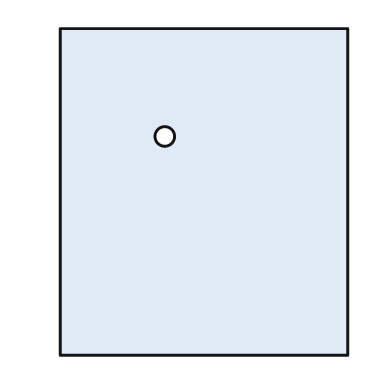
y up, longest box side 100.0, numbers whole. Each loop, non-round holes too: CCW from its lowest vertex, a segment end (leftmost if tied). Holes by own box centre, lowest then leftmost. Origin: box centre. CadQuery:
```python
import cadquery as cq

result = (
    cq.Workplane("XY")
    .moveTo(-44.0, -50.0)
    .lineTo(44.0, -50.0)
    .lineTo(44.0, 50.0)
    .lineTo(-44.0, 50.0)
    .close()
    .moveTo(-12.0, 17.0)
    .circle(3.0)
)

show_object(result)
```